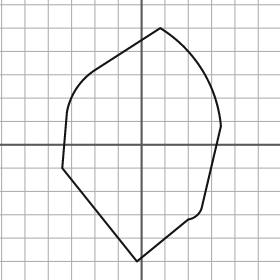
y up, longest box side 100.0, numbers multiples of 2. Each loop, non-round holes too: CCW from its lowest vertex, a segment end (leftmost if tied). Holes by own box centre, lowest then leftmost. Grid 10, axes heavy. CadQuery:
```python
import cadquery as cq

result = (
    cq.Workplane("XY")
    .moveTo(-2.0, -50.0)
    .lineTo(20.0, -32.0)
    .threePointArc((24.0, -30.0), (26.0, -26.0))
    .lineTo(34.0, 8.0)
    .threePointArc((26.0, 32.0), (8.0, 50.0))
    .lineTo(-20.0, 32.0)
    .threePointArc((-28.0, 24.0), (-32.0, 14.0))
    .lineTo(-34.0, -10.0)
    .close()
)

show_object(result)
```